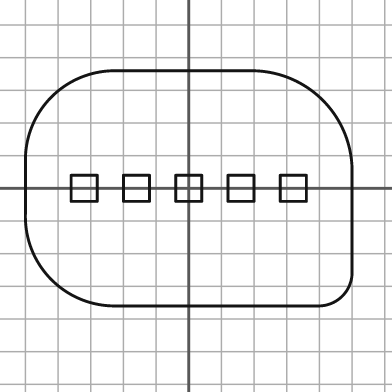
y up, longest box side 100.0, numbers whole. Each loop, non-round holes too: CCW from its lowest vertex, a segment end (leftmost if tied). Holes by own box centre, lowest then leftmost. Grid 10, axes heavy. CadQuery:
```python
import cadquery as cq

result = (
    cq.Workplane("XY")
    .moveTo(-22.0, -36.0)
    .lineTo(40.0, -36.0)
    .threePointArc((47.0, -33.0), (50.0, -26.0))
    .lineTo(50.0, 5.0)
    .threePointArc((41.0, 27.0), (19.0, 36.0))
    .lineTo(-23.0, 36.0)
    .threePointArc((-42.0, 28.0), (-50.0, 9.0))
    .lineTo(-50.0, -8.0)
    .threePointArc((-42.0, -28.0), (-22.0, -36.0))
    .close()
    .moveTo(-36.0, -4.0)
    .lineTo(-28.0, -4.0)
    .lineTo(-28.0, 4.0)
    .lineTo(-36.0, 4.0)
    .close()
    .moveTo(-20.0, -4.0)
    .lineTo(-12.0, -4.0)
    .lineTo(-12.0, 4.0)
    .lineTo(-20.0, 4.0)
    .close()
    .moveTo(-4.0, -4.0)
    .lineTo(4.0, -4.0)
    .lineTo(4.0, 4.0)
    .lineTo(-4.0, 4.0)
    .close()
    .moveTo(12.0, -4.0)
    .lineTo(20.0, -4.0)
    .lineTo(20.0, 4.0)
    .lineTo(12.0, 4.0)
    .close()
    .moveTo(28.0, -4.0)
    .lineTo(36.0, -4.0)
    .lineTo(36.0, 4.0)
    .lineTo(28.0, 4.0)
    .close()
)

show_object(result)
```